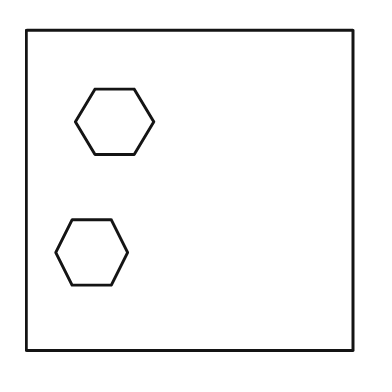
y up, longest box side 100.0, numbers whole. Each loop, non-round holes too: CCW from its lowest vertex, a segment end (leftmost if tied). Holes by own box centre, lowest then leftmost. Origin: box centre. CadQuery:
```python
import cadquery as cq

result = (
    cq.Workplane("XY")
    .moveTo(-50.0, -49.0)
    .lineTo(50.0, -49.0)
    .lineTo(50.0, 49.0)
    .lineTo(-50.0, 49.0)
    .close()
    .moveTo(-36.0, -29.0)
    .lineTo(-24.0, -29.0)
    .lineTo(-19.0, -19.0)
    .lineTo(-24.0, -9.0)
    .lineTo(-36.0, -9.0)
    .lineTo(-41.0, -19.0)
    .close()
    .moveTo(-29.0, 11.0)
    .lineTo(-17.0, 11.0)
    .lineTo(-11.0, 21.0)
    .lineTo(-17.0, 31.0)
    .lineTo(-29.0, 31.0)
    .lineTo(-35.0, 21.0)
    .close()
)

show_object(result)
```